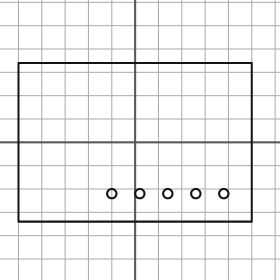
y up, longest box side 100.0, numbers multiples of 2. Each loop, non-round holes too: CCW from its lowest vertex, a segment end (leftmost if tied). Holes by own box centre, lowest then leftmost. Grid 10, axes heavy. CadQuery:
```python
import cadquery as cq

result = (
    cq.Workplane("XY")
    .moveTo(-50.0, -34.0)
    .lineTo(50.0, -34.0)
    .lineTo(50.0, 34.0)
    .lineTo(-50.0, 34.0)
    .close()
    .moveTo(-10.0, -22.0)
    .circle(2.0)
    .moveTo(2.0, -22.0)
    .circle(2.0)
    .moveTo(14.0, -22.0)
    .circle(2.0)
    .moveTo(26.0, -22.0)
    .circle(2.0)
    .moveTo(38.0, -22.0)
    .circle(2.0)
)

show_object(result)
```